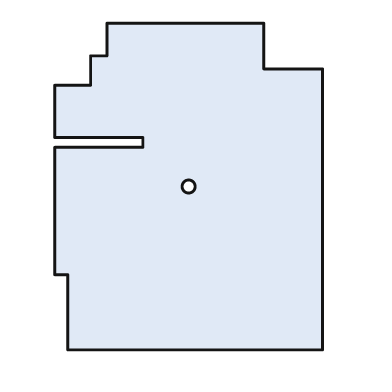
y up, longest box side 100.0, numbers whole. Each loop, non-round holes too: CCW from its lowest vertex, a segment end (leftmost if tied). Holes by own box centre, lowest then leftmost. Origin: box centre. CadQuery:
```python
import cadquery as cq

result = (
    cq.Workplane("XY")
    .moveTo(-37.0, -50.0)
    .lineTo(41.0, -50.0)
    .lineTo(41.0, 36.0)
    .lineTo(23.0, 36.0)
    .lineTo(23.0, 50.0)
    .lineTo(-25.0, 50.0)
    .lineTo(-25.0, 40.0)
    .lineTo(-30.0, 40.0)
    .lineTo(-30.0, 31.0)
    .lineTo(-41.0, 31.0)
    .lineTo(-41.0, 15.0)
    .lineTo(-14.0, 15.0)
    .lineTo(-14.0, 12.0)
    .lineTo(-41.0, 12.0)
    .lineTo(-41.0, -27.0)
    .lineTo(-37.0, -27.0)
    .close()
    .moveTo(0.0, 0.0)
    .circle(2.0)
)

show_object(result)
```